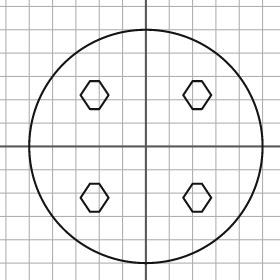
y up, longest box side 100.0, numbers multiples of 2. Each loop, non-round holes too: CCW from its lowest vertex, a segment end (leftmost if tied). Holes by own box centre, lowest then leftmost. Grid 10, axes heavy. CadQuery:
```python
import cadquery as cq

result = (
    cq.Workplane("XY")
    .moveTo(0.0, 0.0)
    .circle(50.0)
    .moveTo(-24.0, -28.0)
    .lineTo(-20.0, -28.0)
    .lineTo(-16.0, -22.0)
    .lineTo(-20.0, -16.0)
    .lineTo(-24.0, -16.0)
    .lineTo(-28.0, -22.0)
    .close()
    .moveTo(20.0, -28.0)
    .lineTo(24.0, -28.0)
    .lineTo(28.0, -22.0)
    .lineTo(24.0, -16.0)
    .lineTo(20.0, -16.0)
    .lineTo(16.0, -22.0)
    .close()
    .moveTo(-24.0, 16.0)
    .lineTo(-20.0, 16.0)
    .lineTo(-16.0, 22.0)
    .lineTo(-20.0, 28.0)
    .lineTo(-24.0, 28.0)
    .lineTo(-28.0, 22.0)
    .close()
    .moveTo(20.0, 16.0)
    .lineTo(24.0, 16.0)
    .lineTo(28.0, 22.0)
    .lineTo(24.0, 28.0)
    .lineTo(20.0, 28.0)
    .lineTo(16.0, 22.0)
    .close()
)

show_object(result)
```